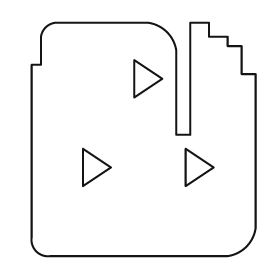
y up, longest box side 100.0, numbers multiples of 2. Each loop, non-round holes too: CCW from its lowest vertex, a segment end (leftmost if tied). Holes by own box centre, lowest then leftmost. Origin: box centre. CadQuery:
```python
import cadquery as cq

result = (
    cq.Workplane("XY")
    .moveTo(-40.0, -50.0)
    .lineTo(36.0, -50.0)
    .threePointArc((44.0, -46.0), (48.0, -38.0))
    .lineTo(48.0, 28.0)
    .lineTo(42.0, 28.0)
    .lineTo(42.0, 40.0)
    .lineTo(36.0, 40.0)
    .lineTo(36.0, 44.0)
    .lineTo(28.0, 44.0)
    .lineTo(28.0, 50.0)
    .lineTo(20.0, 50.0)
    .lineTo(20.0, 2.0)
    .lineTo(14.0, 2.0)
    .lineTo(14.0, 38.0)
    .threePointArc((10.0, 46.0), (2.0, 50.0))
    .lineTo(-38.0, 50.0)
    .threePointArc((-42.0, 48.0), (-44.0, 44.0))
    .lineTo(-44.0, 32.0)
    .lineTo(-48.0, 32.0)
    .lineTo(-48.0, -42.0)
    .threePointArc((-46.0, -48.0), (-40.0, -50.0))
    .close()
    .moveTo(-26.0, -20.0)
    .lineTo(-14.0, -12.0)
    .lineTo(-26.0, -4.0)
    .close()
    .moveTo(18.0, -20.0)
    .lineTo(30.0, -12.0)
    .lineTo(18.0, -4.0)
    .close()
    .moveTo(-4.0, 18.0)
    .lineTo(8.0, 26.0)
    .lineTo(-4.0, 34.0)
    .close()
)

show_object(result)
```